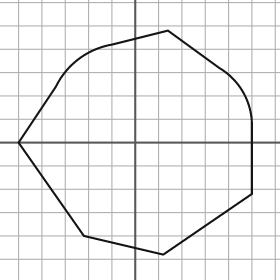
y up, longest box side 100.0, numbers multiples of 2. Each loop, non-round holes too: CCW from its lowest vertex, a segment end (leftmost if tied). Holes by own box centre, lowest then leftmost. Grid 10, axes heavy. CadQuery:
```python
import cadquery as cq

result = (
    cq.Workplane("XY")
    .moveTo(12.0, -48.0)
    .lineTo(50.0, -22.0)
    .lineTo(50.0, 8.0)
    .threePointArc((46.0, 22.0), (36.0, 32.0))
    .lineTo(14.0, 48.0)
    .lineTo(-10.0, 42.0)
    .threePointArc((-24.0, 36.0), (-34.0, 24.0))
    .lineTo(-50.0, 0.0)
    .lineTo(-22.0, -40.0)
    .close()
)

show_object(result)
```